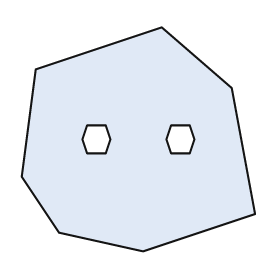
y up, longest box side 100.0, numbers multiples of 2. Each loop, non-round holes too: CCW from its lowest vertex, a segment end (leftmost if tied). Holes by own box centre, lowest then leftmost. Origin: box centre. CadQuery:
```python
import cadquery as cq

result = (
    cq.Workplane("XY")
    .moveTo(2.0, -48.0)
    .lineTo(50.0, -32.0)
    .lineTo(40.0, 22.0)
    .lineTo(10.0, 48.0)
    .lineTo(-44.0, 30.0)
    .lineTo(-50.0, -16.0)
    .lineTo(-34.0, -40.0)
    .close()
    .moveTo(-22.0, -6.0)
    .lineTo(-14.0, -6.0)
    .lineTo(-12.0, 0.0)
    .lineTo(-14.0, 6.0)
    .lineTo(-22.0, 6.0)
    .lineTo(-24.0, 0.0)
    .close()
    .moveTo(14.0, -6.0)
    .lineTo(22.0, -6.0)
    .lineTo(24.0, 0.0)
    .lineTo(22.0, 6.0)
    .lineTo(14.0, 6.0)
    .lineTo(12.0, 0.0)
    .close()
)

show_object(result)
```